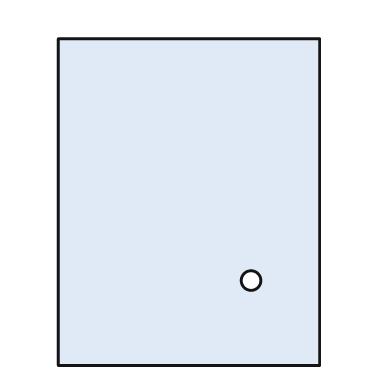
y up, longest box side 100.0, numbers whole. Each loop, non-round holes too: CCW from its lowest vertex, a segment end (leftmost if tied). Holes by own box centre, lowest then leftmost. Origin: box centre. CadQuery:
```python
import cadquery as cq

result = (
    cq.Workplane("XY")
    .moveTo(-40.0, -50.0)
    .lineTo(40.0, -50.0)
    .lineTo(40.0, 50.0)
    .lineTo(-40.0, 50.0)
    .close()
    .moveTo(19.0, -24.0)
    .circle(3.0)
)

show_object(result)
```